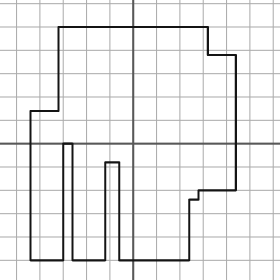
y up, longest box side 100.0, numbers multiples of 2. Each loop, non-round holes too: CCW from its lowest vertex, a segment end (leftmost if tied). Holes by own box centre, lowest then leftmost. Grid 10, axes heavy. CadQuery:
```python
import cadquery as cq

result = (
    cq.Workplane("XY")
    .moveTo(-44.0, -50.0)
    .lineTo(-30.0, -50.0)
    .lineTo(-30.0, 0.0)
    .lineTo(-26.0, 0.0)
    .lineTo(-26.0, -50.0)
    .lineTo(-12.0, -50.0)
    .lineTo(-12.0, -8.0)
    .lineTo(-6.0, -8.0)
    .lineTo(-6.0, -50.0)
    .lineTo(24.0, -50.0)
    .lineTo(24.0, -24.0)
    .lineTo(28.0, -24.0)
    .lineTo(28.0, -20.0)
    .lineTo(44.0, -20.0)
    .lineTo(44.0, 38.0)
    .lineTo(32.0, 38.0)
    .lineTo(32.0, 50.0)
    .lineTo(-32.0, 50.0)
    .lineTo(-32.0, 14.0)
    .lineTo(-44.0, 14.0)
    .close()
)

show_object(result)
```